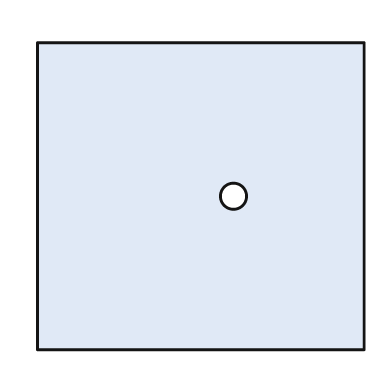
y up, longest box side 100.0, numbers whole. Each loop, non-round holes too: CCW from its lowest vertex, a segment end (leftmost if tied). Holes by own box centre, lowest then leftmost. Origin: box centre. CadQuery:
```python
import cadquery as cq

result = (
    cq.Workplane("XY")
    .moveTo(-50.0, -47.0)
    .lineTo(50.0, -47.0)
    .lineTo(50.0, 47.0)
    .lineTo(-50.0, 47.0)
    .close()
    .moveTo(10.0, 0.0)
    .circle(4.0)
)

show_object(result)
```